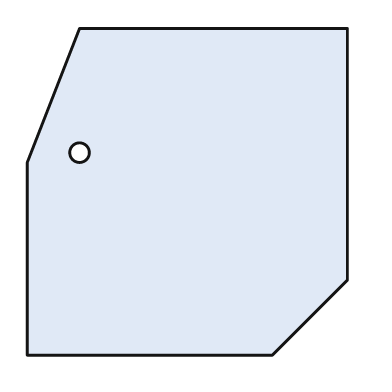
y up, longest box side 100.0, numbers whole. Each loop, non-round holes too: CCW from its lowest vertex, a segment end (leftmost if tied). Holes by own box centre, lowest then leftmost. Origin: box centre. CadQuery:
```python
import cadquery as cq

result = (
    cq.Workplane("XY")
    .moveTo(-49.0, -50.0)
    .lineTo(26.0, -50.0)
    .lineTo(49.0, -27.0)
    .lineTo(49.0, 50.0)
    .lineTo(-33.0, 50.0)
    .lineTo(-49.0, 9.0)
    .close()
    .moveTo(-33.0, 12.0)
    .circle(3.0)
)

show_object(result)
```